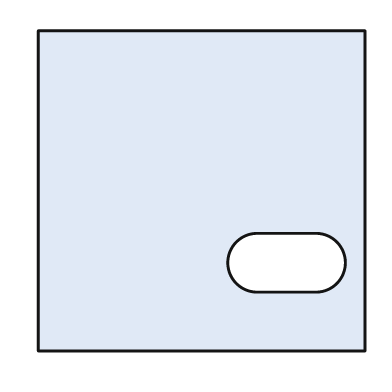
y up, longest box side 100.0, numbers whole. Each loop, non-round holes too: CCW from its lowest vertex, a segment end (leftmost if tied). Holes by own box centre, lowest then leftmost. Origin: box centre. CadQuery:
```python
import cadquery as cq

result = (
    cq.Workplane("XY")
    .moveTo(-50.0, -49.0)
    .lineTo(50.0, -49.0)
    .lineTo(50.0, 49.0)
    .lineTo(-50.0, 49.0)
    .close()
    .moveTo(17.0, -31.0)
    .lineTo(35.0, -31.0)
    .threePointArc((44.0, -22.0), (35.0, -13.0))
    .lineTo(17.0, -13.0)
    .threePointArc((8.0, -22.0), (17.0, -31.0))
    .close()
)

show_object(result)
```